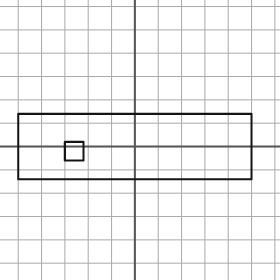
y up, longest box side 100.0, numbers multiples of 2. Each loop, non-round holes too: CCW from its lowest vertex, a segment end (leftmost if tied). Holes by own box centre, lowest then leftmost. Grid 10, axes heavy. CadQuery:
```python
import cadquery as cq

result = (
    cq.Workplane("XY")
    .moveTo(-50.0, -14.0)
    .lineTo(50.0, -14.0)
    .lineTo(50.0, 14.0)
    .lineTo(-50.0, 14.0)
    .close()
    .moveTo(-30.0, -6.0)
    .lineTo(-22.0, -6.0)
    .lineTo(-22.0, 2.0)
    .lineTo(-30.0, 2.0)
    .close()
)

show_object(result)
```